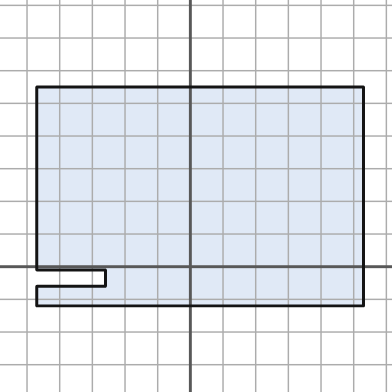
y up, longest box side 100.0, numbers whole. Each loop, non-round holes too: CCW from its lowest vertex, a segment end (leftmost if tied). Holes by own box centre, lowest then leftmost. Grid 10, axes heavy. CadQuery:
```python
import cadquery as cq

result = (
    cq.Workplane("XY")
    .moveTo(-47.0, -12.0)
    .lineTo(53.0, -12.0)
    .lineTo(53.0, 55.0)
    .lineTo(-47.0, 55.0)
    .lineTo(-47.0, -1.0)
    .lineTo(-26.0, -1.0)
    .lineTo(-26.0, -6.0)
    .lineTo(-47.0, -6.0)
    .close()
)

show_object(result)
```